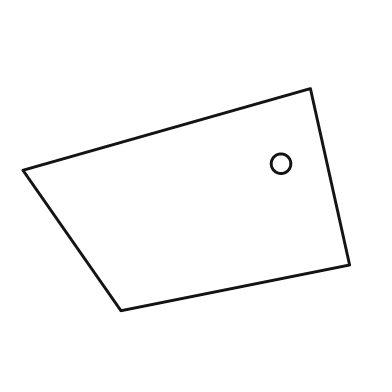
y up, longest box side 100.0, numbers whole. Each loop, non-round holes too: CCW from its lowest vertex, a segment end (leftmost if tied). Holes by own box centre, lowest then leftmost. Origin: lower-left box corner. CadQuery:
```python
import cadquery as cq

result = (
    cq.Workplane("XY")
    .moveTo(30.0, 0.0)
    .lineTo(100.0, 14.0)
    .lineTo(88.0, 68.0)
    .lineTo(0.0, 43.0)
    .close()
    .moveTo(79.0, 45.0)
    .circle(3.0)
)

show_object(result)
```